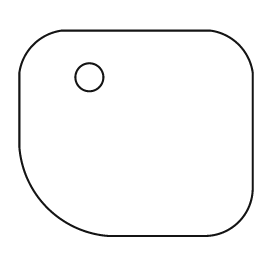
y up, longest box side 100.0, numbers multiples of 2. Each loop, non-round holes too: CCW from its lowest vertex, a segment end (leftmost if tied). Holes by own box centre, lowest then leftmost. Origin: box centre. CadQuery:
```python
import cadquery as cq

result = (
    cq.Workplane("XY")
    .moveTo(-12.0, -44.0)
    .lineTo(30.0, -44.0)
    .threePointArc((44.0, -38.0), (50.0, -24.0))
    .lineTo(50.0, 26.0)
    .threePointArc((44.0, 38.0), (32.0, 44.0))
    .lineTo(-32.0, 44.0)
    .threePointArc((-44.0, 38.0), (-50.0, 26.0))
    .lineTo(-50.0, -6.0)
    .threePointArc((-38.0, -32.0), (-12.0, -44.0))
    .close()
    .moveTo(-20.0, 24.0)
    .circle(6.0)
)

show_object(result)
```